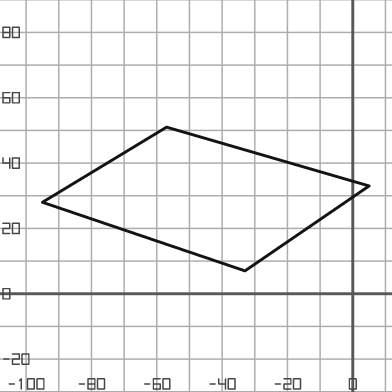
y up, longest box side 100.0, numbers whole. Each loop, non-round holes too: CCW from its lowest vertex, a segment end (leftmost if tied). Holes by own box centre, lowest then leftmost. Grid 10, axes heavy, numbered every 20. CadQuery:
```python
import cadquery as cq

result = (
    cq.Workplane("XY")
    .moveTo(-33.0, 7.0)
    .lineTo(5.0, 33.0)
    .lineTo(-57.0, 51.0)
    .lineTo(-95.0, 28.0)
    .close()
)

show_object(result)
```